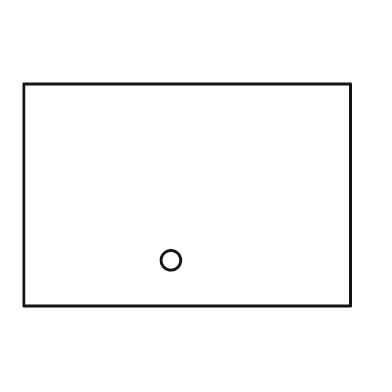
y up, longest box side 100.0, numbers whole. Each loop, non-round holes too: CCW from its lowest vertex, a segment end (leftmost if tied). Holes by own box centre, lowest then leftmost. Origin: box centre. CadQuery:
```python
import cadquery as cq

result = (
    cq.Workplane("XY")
    .moveTo(-50.0, -34.0)
    .lineTo(50.0, -34.0)
    .lineTo(50.0, 34.0)
    .lineTo(-50.0, 34.0)
    .close()
    .moveTo(-5.0, -20.0)
    .circle(3.0)
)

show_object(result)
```